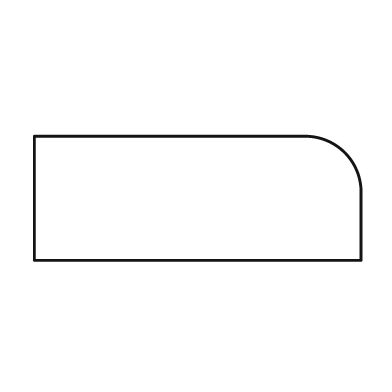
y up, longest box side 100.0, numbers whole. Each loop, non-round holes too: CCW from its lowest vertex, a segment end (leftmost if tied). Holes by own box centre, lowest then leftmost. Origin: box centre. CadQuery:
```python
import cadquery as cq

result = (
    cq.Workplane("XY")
    .moveTo(-50.0, -19.0)
    .lineTo(50.0, -19.0)
    .lineTo(50.0, 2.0)
    .threePointArc((45.0, 14.0), (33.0, 19.0))
    .lineTo(-50.0, 19.0)
    .close()
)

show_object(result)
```